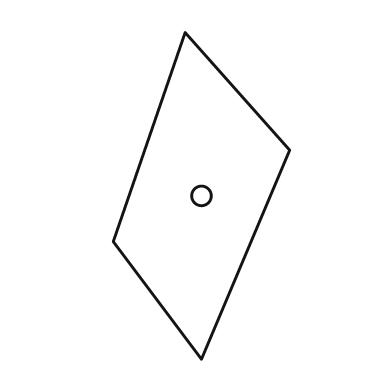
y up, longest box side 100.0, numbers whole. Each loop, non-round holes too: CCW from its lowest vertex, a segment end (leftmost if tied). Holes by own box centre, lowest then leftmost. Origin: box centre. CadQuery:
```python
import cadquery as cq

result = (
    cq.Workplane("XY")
    .moveTo(0.0, -50.0)
    .lineTo(27.0, 14.0)
    .lineTo(-5.0, 50.0)
    .lineTo(-27.0, -14.0)
    .close()
    .moveTo(0.0, 0.0)
    .circle(3.0)
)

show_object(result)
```